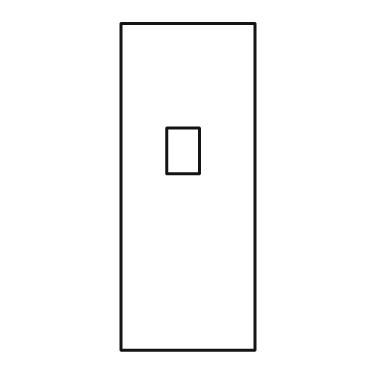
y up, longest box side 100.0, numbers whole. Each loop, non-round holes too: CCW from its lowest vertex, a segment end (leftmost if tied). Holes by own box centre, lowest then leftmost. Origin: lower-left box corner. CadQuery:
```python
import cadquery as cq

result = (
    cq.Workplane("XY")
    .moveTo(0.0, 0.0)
    .lineTo(41.0, 0.0)
    .lineTo(41.0, 100.0)
    .lineTo(0.0, 100.0)
    .close()
    .moveTo(14.0, 54.0)
    .lineTo(24.0, 54.0)
    .lineTo(24.0, 68.0)
    .lineTo(14.0, 68.0)
    .close()
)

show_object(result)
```